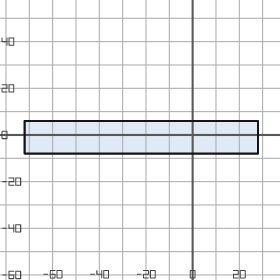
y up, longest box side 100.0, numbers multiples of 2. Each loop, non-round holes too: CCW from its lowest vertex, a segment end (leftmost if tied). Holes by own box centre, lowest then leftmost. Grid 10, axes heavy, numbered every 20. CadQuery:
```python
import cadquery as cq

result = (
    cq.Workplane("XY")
    .moveTo(-72.0, -8.0)
    .lineTo(28.0, -8.0)
    .lineTo(28.0, 6.0)
    .lineTo(-72.0, 6.0)
    .close()
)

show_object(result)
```